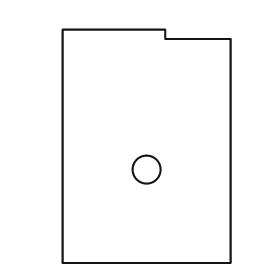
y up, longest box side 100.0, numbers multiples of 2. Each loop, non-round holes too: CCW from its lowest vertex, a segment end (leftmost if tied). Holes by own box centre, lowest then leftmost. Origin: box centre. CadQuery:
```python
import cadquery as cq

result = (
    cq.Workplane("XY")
    .moveTo(-36.0, -50.0)
    .lineTo(36.0, -50.0)
    .lineTo(36.0, 46.0)
    .lineTo(8.0, 46.0)
    .lineTo(8.0, 50.0)
    .lineTo(-36.0, 50.0)
    .close()
    .moveTo(0.0, -10.0)
    .circle(6.0)
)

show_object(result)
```